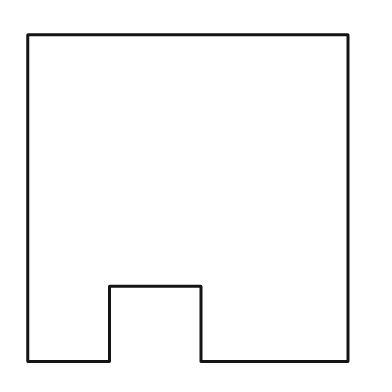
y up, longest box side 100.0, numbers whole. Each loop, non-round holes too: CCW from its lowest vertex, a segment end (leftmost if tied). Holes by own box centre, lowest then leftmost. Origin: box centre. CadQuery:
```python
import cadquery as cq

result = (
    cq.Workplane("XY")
    .moveTo(-49.0, -50.0)
    .lineTo(-24.0, -50.0)
    .lineTo(-24.0, -27.0)
    .lineTo(4.0, -27.0)
    .lineTo(4.0, -50.0)
    .lineTo(49.0, -50.0)
    .lineTo(49.0, 50.0)
    .lineTo(-49.0, 50.0)
    .close()
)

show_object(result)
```